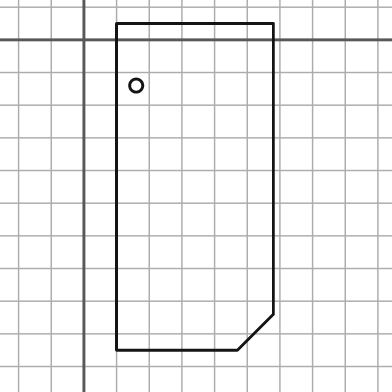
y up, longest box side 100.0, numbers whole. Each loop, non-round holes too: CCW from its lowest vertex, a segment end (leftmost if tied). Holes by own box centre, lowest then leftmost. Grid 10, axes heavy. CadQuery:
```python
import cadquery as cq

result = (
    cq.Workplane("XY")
    .moveTo(10.0, -95.0)
    .lineTo(47.0, -95.0)
    .lineTo(58.0, -84.0)
    .lineTo(58.0, 5.0)
    .lineTo(10.0, 5.0)
    .close()
    .moveTo(16.0, -14.0)
    .circle(2.0)
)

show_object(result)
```